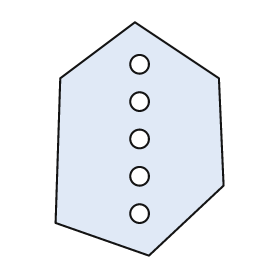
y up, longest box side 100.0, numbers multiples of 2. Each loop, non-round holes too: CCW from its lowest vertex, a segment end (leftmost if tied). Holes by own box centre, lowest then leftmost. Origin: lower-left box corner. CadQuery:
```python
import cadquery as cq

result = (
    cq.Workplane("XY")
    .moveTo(40.0, 0.0)
    .lineTo(72.0, 30.0)
    .lineTo(70.0, 76.0)
    .lineTo(34.0, 100.0)
    .lineTo(2.0, 76.0)
    .lineTo(0.0, 14.0)
    .close()
    .moveTo(36.0, 18.0)
    .circle(4.0)
    .moveTo(36.0, 34.0)
    .circle(4.0)
    .moveTo(36.0, 50.0)
    .circle(4.0)
    .moveTo(36.0, 66.0)
    .circle(4.0)
    .moveTo(36.0, 82.0)
    .circle(4.0)
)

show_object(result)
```